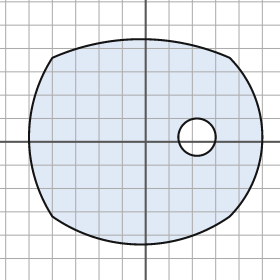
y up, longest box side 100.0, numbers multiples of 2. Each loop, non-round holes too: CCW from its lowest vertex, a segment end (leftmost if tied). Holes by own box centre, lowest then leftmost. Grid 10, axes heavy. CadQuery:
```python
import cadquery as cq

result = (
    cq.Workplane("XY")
    .moveTo(-40.0, -32.0)
    .threePointArc((-2.0, -44.0), (36.0, -32.0))
    .threePointArc((50.0, 2.0), (36.0, 36.0))
    .threePointArc((-2.0, 44.0), (-40.0, 36.0))
    .threePointArc((-50.0, 2.0), (-40.0, -32.0))
    .close()
    .moveTo(22.0, 2.0)
    .circle(8.0)
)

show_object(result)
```